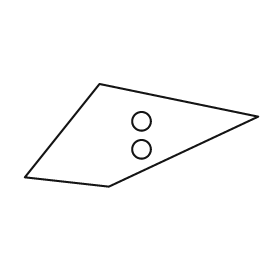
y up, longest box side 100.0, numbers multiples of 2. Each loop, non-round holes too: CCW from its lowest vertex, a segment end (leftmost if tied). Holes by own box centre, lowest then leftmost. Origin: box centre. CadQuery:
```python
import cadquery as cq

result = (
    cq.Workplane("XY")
    .moveTo(-14.0, -22.0)
    .lineTo(50.0, 8.0)
    .lineTo(-18.0, 22.0)
    .lineTo(-50.0, -18.0)
    .close()
    .moveTo(0.0, -6.0)
    .circle(4.0)
    .moveTo(0.0, 6.0)
    .circle(4.0)
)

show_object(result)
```